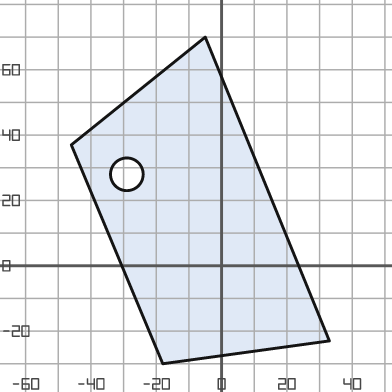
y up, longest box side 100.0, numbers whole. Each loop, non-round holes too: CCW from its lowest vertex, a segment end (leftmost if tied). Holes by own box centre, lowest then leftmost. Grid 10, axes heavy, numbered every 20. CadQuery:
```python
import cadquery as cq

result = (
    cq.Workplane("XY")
    .moveTo(-18.0, -30.0)
    .lineTo(33.0, -23.0)
    .lineTo(-5.0, 70.0)
    .lineTo(-46.0, 37.0)
    .close()
    .moveTo(-29.0, 28.0)
    .circle(5.0)
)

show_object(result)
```